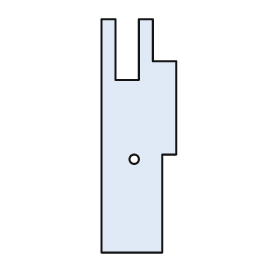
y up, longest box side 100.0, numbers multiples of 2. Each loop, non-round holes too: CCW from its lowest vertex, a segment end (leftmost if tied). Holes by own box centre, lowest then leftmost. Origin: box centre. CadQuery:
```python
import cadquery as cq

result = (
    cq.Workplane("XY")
    .moveTo(-16.0, -50.0)
    .lineTo(10.0, -50.0)
    .lineTo(10.0, -8.0)
    .lineTo(16.0, -8.0)
    .lineTo(16.0, 32.0)
    .lineTo(6.0, 32.0)
    .lineTo(6.0, 50.0)
    .lineTo(0.0, 50.0)
    .lineTo(0.0, 24.0)
    .lineTo(-10.0, 24.0)
    .lineTo(-10.0, 50.0)
    .lineTo(-16.0, 50.0)
    .close()
    .moveTo(-2.0, -10.0)
    .circle(2.0)
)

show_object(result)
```